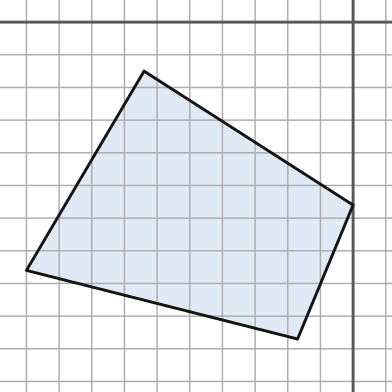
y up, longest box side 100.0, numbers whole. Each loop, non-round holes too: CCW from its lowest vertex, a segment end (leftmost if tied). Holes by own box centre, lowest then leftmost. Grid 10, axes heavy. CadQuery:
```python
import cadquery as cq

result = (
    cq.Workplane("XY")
    .moveTo(-17.0, -97.0)
    .lineTo(0.0, -56.0)
    .lineTo(-64.0, -15.0)
    .lineTo(-100.0, -76.0)
    .close()
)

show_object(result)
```